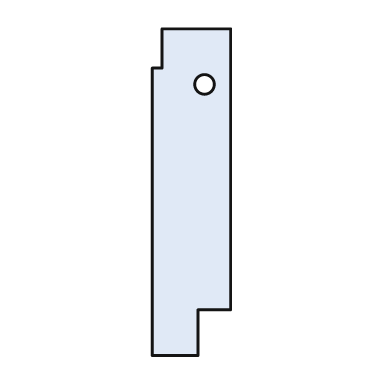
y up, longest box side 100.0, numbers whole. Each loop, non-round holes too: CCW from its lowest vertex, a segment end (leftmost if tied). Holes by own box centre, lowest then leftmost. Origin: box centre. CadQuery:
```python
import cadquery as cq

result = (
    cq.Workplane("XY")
    .moveTo(-12.0, -50.0)
    .lineTo(2.0, -50.0)
    .lineTo(2.0, -36.0)
    .lineTo(12.0, -36.0)
    .lineTo(12.0, 50.0)
    .lineTo(-9.0, 50.0)
    .lineTo(-9.0, 38.0)
    .lineTo(-12.0, 38.0)
    .close()
    .moveTo(4.0, 33.0)
    .circle(3.0)
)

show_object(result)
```